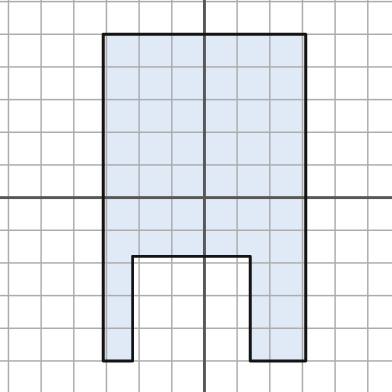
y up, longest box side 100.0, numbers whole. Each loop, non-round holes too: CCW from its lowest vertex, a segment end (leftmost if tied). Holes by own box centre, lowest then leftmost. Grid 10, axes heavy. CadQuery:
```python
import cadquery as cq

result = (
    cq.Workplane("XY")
    .moveTo(-31.0, -50.0)
    .lineTo(-22.0, -50.0)
    .lineTo(-22.0, -18.0)
    .lineTo(14.0, -18.0)
    .lineTo(14.0, -50.0)
    .lineTo(31.0, -50.0)
    .lineTo(31.0, 50.0)
    .lineTo(-31.0, 50.0)
    .close()
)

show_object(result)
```